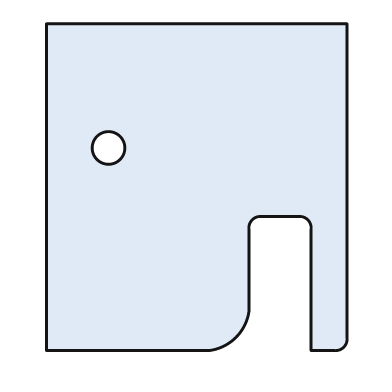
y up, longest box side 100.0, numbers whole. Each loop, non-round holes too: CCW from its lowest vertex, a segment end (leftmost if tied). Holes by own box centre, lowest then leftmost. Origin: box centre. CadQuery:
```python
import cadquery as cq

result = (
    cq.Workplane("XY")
    .moveTo(-46.0, -50.0)
    .lineTo(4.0, -50.0)
    .threePointArc((12.0, -46.0), (16.0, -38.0))
    .lineTo(16.0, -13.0)
    .threePointArc((17.0, -10.0), (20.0, -9.0))
    .lineTo(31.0, -9.0)
    .threePointArc((34.0, -10.0), (35.0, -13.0))
    .lineTo(35.0, -50.0)
    .lineTo(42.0, -50.0)
    .threePointArc((45.0, -49.0), (46.0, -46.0))
    .lineTo(46.0, 50.0)
    .lineTo(-46.0, 50.0)
    .close()
    .moveTo(-27.0, 12.0)
    .circle(5.0)
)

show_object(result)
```